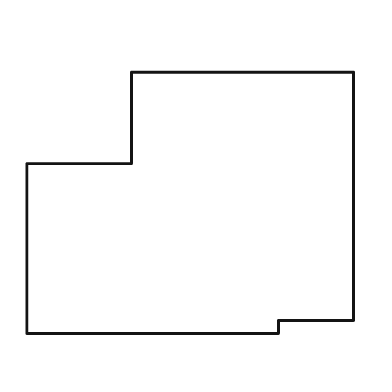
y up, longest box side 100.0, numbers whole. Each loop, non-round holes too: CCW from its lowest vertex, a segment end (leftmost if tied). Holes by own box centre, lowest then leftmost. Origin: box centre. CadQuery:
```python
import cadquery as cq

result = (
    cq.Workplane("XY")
    .moveTo(-50.0, -40.0)
    .lineTo(27.0, -40.0)
    .lineTo(27.0, -36.0)
    .lineTo(50.0, -36.0)
    .lineTo(50.0, 40.0)
    .lineTo(-18.0, 40.0)
    .lineTo(-18.0, 12.0)
    .lineTo(-50.0, 12.0)
    .close()
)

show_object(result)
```